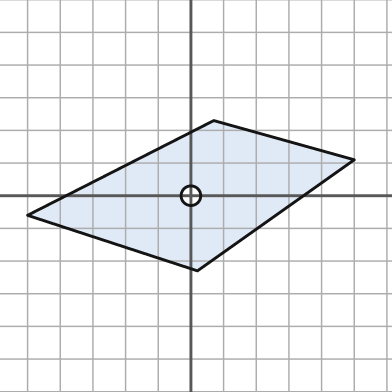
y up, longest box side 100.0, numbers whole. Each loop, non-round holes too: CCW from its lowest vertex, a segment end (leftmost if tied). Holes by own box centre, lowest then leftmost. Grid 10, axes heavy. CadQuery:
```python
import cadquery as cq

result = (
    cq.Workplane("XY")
    .moveTo(2.0, -23.0)
    .lineTo(50.0, 11.0)
    .lineTo(7.0, 23.0)
    .lineTo(-50.0, -6.0)
    .close()
    .moveTo(0.0, 0.0)
    .circle(3.0)
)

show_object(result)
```